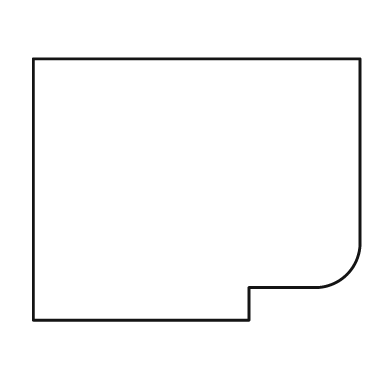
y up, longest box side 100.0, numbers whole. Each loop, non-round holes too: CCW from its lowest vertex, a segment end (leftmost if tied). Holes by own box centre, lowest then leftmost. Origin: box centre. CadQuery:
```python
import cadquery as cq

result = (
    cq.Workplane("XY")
    .moveTo(-50.0, -40.0)
    .lineTo(16.0, -40.0)
    .lineTo(16.0, -30.0)
    .lineTo(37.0, -30.0)
    .threePointArc((46.0, -26.0), (50.0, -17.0))
    .lineTo(50.0, 40.0)
    .lineTo(-50.0, 40.0)
    .close()
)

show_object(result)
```